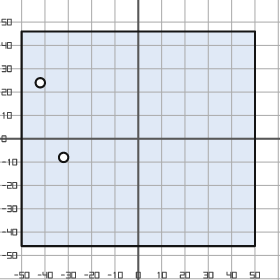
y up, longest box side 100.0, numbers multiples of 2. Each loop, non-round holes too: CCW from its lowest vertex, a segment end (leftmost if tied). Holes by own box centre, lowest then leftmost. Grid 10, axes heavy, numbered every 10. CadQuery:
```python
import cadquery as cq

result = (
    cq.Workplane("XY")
    .moveTo(-50.0, -46.0)
    .lineTo(50.0, -46.0)
    .lineTo(50.0, 46.0)
    .lineTo(-50.0, 46.0)
    .close()
    .moveTo(-32.0, -8.0)
    .circle(2.0)
    .moveTo(-42.0, 24.0)
    .circle(2.0)
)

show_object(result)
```